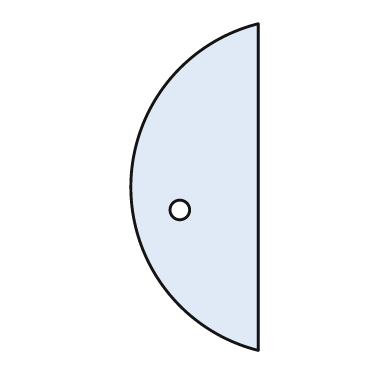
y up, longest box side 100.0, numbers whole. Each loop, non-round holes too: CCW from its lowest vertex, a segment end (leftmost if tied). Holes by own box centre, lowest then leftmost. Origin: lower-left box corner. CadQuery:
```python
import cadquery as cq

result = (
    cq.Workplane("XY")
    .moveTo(39.0, 0.0)
    .lineTo(39.0, 100.0)
    .threePointArc((0.0, 50.0), (39.0, 0.0))
    .close()
    .moveTo(15.0, 43.0)
    .circle(3.0)
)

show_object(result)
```